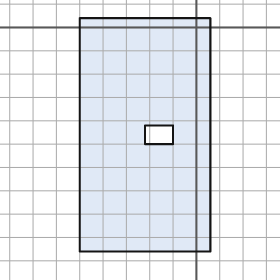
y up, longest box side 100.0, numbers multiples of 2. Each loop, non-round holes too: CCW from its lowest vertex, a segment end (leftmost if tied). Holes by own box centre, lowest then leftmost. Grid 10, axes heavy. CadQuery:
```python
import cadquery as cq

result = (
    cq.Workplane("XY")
    .moveTo(-50.0, -96.0)
    .lineTo(6.0, -96.0)
    .lineTo(6.0, 4.0)
    .lineTo(-50.0, 4.0)
    .close()
    .moveTo(-22.0, -50.0)
    .lineTo(-10.0, -50.0)
    .lineTo(-10.0, -42.0)
    .lineTo(-22.0, -42.0)
    .close()
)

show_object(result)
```